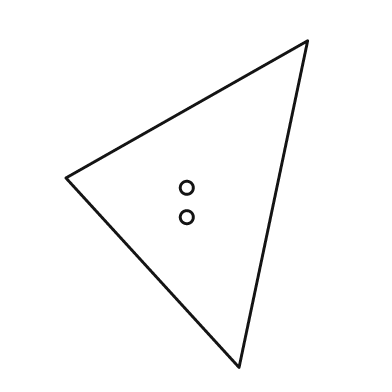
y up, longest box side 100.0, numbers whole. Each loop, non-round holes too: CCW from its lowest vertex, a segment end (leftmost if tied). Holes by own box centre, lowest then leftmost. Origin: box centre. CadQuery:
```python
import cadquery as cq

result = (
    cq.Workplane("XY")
    .moveTo(16.0, -50.0)
    .lineTo(37.0, 50.0)
    .lineTo(-37.0, 8.0)
    .close()
    .moveTo(0.0, -4.0)
    .circle(2.0)
    .moveTo(0.0, 5.0)
    .circle(2.0)
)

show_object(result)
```